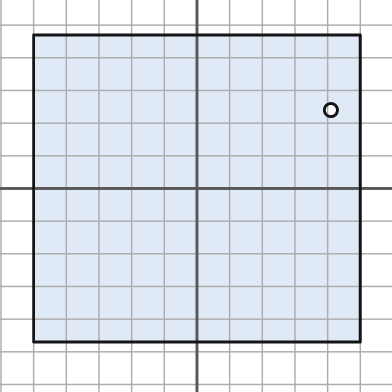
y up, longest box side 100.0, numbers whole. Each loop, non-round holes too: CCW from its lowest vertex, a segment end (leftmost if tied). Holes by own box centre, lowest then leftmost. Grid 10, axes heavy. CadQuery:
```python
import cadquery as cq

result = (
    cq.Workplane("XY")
    .moveTo(-50.0, -47.0)
    .lineTo(50.0, -47.0)
    .lineTo(50.0, 47.0)
    .lineTo(-50.0, 47.0)
    .close()
    .moveTo(41.0, 24.0)
    .circle(2.0)
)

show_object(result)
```